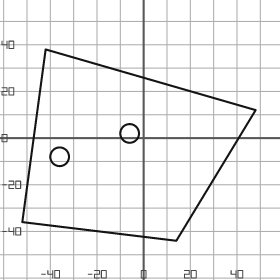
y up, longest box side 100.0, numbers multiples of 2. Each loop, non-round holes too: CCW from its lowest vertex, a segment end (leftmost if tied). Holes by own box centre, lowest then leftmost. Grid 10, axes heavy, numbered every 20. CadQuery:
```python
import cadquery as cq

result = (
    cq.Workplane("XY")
    .moveTo(14.0, -44.0)
    .lineTo(48.0, 12.0)
    .lineTo(-42.0, 38.0)
    .lineTo(-52.0, -36.0)
    .close()
    .moveTo(-36.0, -8.0)
    .circle(4.0)
    .moveTo(-6.0, 2.0)
    .circle(4.0)
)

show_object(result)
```